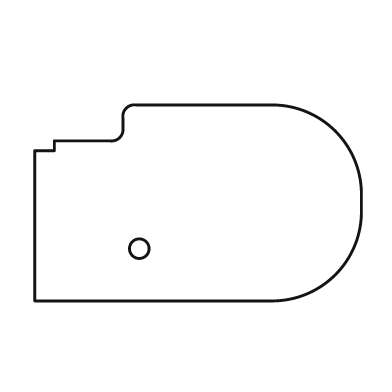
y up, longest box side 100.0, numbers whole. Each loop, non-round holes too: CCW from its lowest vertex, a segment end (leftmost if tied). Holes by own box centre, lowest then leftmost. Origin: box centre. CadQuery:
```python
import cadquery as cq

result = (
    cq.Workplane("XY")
    .moveTo(-50.0, -30.0)
    .lineTo(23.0, -30.0)
    .threePointArc((42.0, -22.0), (50.0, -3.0))
    .lineTo(50.0, 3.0)
    .threePointArc((42.0, 22.0), (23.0, 30.0))
    .lineTo(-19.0, 30.0)
    .threePointArc((-22.0, 29.0), (-23.0, 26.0))
    .lineTo(-23.0, 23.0)
    .threePointArc((-24.0, 20.0), (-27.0, 19.0))
    .lineTo(-44.0, 19.0)
    .lineTo(-44.0, 16.0)
    .lineTo(-50.0, 16.0)
    .close()
    .moveTo(-18.0, -14.0)
    .circle(3.0)
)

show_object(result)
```